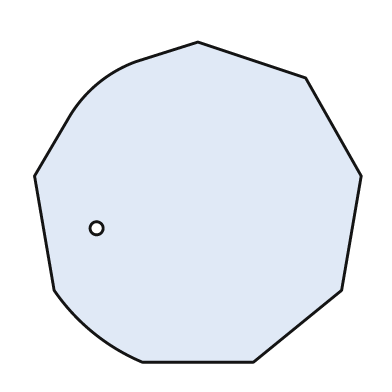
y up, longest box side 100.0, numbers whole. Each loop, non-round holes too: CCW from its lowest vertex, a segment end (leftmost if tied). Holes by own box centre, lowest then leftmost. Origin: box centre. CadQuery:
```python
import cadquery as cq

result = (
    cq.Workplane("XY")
    .moveTo(-17.0, -49.0)
    .lineTo(17.0, -49.0)
    .lineTo(44.0, -27.0)
    .lineTo(50.0, 8.0)
    .lineTo(33.0, 38.0)
    .lineTo(0.0, 49.0)
    .lineTo(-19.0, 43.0)
    .threePointArc((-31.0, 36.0), (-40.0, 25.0))
    .lineTo(-50.0, 8.0)
    .lineTo(-44.0, -27.0)
    .threePointArc((-32.0, -40.0), (-17.0, -49.0))
    .close()
    .moveTo(-31.0, -8.0)
    .circle(2.0)
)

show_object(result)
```